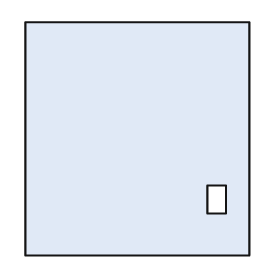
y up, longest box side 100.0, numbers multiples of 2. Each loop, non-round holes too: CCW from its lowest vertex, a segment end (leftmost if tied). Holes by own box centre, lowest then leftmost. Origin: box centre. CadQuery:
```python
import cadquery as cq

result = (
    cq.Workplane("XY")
    .moveTo(-48.0, -50.0)
    .lineTo(48.0, -50.0)
    .lineTo(48.0, 50.0)
    .lineTo(-48.0, 50.0)
    .close()
    .moveTo(30.0, -32.0)
    .lineTo(38.0, -32.0)
    .lineTo(38.0, -20.0)
    .lineTo(30.0, -20.0)
    .close()
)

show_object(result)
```